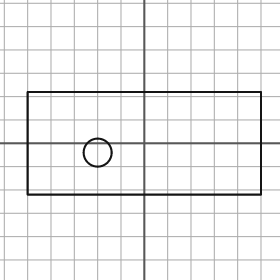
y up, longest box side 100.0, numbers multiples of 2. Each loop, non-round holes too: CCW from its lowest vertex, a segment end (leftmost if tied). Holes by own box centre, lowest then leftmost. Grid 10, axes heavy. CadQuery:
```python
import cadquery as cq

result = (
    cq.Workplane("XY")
    .moveTo(-50.0, -22.0)
    .lineTo(50.0, -22.0)
    .lineTo(50.0, 22.0)
    .lineTo(-50.0, 22.0)
    .close()
    .moveTo(-20.0, -4.0)
    .circle(6.0)
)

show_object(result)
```